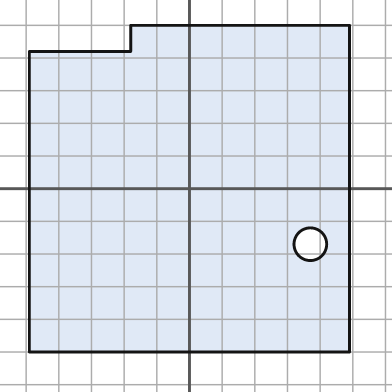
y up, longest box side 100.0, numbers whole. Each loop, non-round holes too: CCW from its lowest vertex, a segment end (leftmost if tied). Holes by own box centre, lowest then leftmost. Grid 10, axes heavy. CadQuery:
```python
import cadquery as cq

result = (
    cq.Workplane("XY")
    .moveTo(-49.0, -50.0)
    .lineTo(49.0, -50.0)
    .lineTo(49.0, 50.0)
    .lineTo(-18.0, 50.0)
    .lineTo(-18.0, 42.0)
    .lineTo(-49.0, 42.0)
    .close()
    .moveTo(37.0, -17.0)
    .circle(5.0)
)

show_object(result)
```